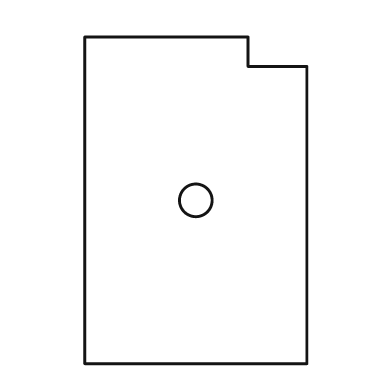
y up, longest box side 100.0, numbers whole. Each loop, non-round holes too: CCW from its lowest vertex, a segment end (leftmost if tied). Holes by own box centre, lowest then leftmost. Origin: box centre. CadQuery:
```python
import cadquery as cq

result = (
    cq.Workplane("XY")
    .moveTo(-34.0, -50.0)
    .lineTo(34.0, -50.0)
    .lineTo(34.0, 41.0)
    .lineTo(16.0, 41.0)
    .lineTo(16.0, 50.0)
    .lineTo(-34.0, 50.0)
    .close()
    .moveTo(0.0, 0.0)
    .circle(5.0)
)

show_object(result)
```